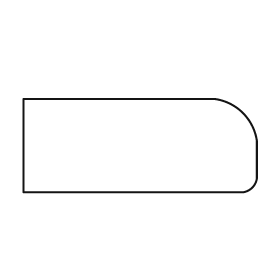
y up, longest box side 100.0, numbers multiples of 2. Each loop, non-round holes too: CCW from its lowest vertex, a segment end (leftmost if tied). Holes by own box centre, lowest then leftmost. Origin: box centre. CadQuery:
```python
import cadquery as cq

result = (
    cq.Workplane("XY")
    .moveTo(-50.0, -20.0)
    .lineTo(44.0, -20.0)
    .threePointArc((48.0, -18.0), (50.0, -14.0))
    .lineTo(50.0, 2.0)
    .threePointArc((44.0, 14.0), (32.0, 20.0))
    .lineTo(-50.0, 20.0)
    .close()
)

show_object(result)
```